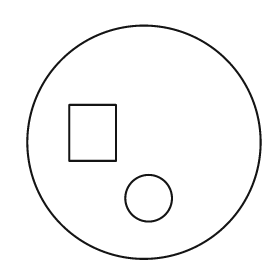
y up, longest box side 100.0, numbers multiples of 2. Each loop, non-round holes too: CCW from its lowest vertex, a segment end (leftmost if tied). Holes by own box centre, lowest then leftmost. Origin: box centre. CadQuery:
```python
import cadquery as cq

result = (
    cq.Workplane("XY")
    .moveTo(0.0, 0.0)
    .circle(50.0)
    .moveTo(2.0, -24.0)
    .circle(10.0)
    .moveTo(-32.0, -8.0)
    .lineTo(-12.0, -8.0)
    .lineTo(-12.0, 16.0)
    .lineTo(-32.0, 16.0)
    .close()
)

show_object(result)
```